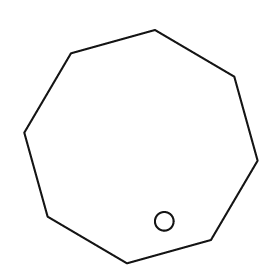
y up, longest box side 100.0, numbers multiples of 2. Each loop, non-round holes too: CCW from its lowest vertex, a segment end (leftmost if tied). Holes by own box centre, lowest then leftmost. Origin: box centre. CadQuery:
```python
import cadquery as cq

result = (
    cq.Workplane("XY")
    .moveTo(-6.0, -50.0)
    .lineTo(30.0, -40.0)
    .lineTo(50.0, -6.0)
    .lineTo(40.0, 30.0)
    .lineTo(6.0, 50.0)
    .lineTo(-30.0, 40.0)
    .lineTo(-50.0, 6.0)
    .lineTo(-40.0, -30.0)
    .close()
    .moveTo(10.0, -32.0)
    .circle(4.0)
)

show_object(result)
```